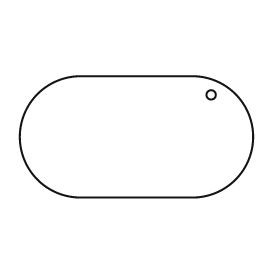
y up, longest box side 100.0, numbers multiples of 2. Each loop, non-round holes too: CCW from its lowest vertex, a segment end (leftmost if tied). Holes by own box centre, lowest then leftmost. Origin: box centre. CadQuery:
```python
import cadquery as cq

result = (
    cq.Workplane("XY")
    .moveTo(-24.0, -26.0)
    .lineTo(24.0, -26.0)
    .threePointArc((50.0, 0.0), (24.0, 26.0))
    .lineTo(-24.0, 26.0)
    .threePointArc((-50.0, 0.0), (-24.0, -26.0))
    .close()
    .moveTo(32.0, 18.0)
    .circle(2.0)
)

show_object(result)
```